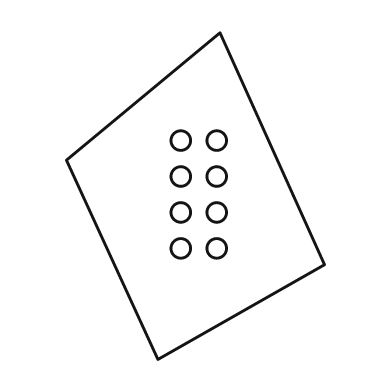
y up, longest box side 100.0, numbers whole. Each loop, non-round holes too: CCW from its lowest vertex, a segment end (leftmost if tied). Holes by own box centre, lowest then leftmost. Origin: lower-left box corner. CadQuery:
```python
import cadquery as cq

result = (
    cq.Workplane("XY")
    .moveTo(28.0, 0.0)
    .lineTo(79.0, 29.0)
    .lineTo(47.0, 100.0)
    .lineTo(0.0, 61.0)
    .close()
    .moveTo(35.0, 34.0)
    .circle(3.0)
    .moveTo(46.0, 34.0)
    .circle(3.0)
    .moveTo(35.0, 45.0)
    .circle(3.0)
    .moveTo(46.0, 45.0)
    .circle(3.0)
    .moveTo(35.0, 56.0)
    .circle(3.0)
    .moveTo(46.0, 56.0)
    .circle(3.0)
    .moveTo(35.0, 67.0)
    .circle(3.0)
    .moveTo(46.0, 67.0)
    .circle(3.0)
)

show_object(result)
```